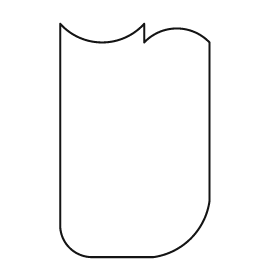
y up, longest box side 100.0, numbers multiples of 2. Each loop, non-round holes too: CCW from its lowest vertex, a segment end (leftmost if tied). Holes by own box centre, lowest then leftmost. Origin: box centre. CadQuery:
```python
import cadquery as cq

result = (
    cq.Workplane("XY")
    .moveTo(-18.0, -50.0)
    .lineTo(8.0, -50.0)
    .threePointArc((24.0, -42.0), (32.0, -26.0))
    .lineTo(32.0, 42.0)
    .threePointArc((18.0, 48.0), (4.0, 42.0))
    .lineTo(4.0, 50.0)
    .threePointArc((-14.0, 42.0), (-32.0, 50.0))
    .lineTo(-32.0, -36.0)
    .threePointArc((-28.0, -46.0), (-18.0, -50.0))
    .close()
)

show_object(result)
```